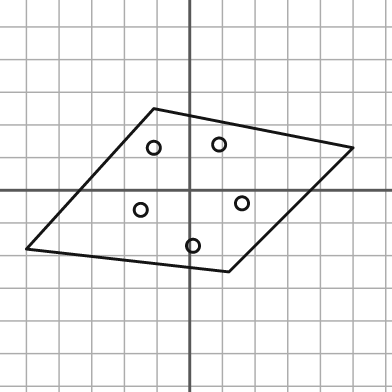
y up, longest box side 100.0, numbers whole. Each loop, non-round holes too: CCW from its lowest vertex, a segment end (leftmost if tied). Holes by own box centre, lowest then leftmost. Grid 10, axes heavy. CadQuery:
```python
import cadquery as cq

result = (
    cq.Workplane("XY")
    .moveTo(12.0, -25.0)
    .lineTo(50.0, 13.0)
    .lineTo(-11.0, 25.0)
    .lineTo(-50.0, -18.0)
    .close()
    .moveTo(1.0, -17.0)
    .circle(2.0)
    .moveTo(-15.0, -6.0)
    .circle(2.0)
    .moveTo(16.0, -4.0)
    .circle(2.0)
    .moveTo(-11.0, 13.0)
    .circle(2.0)
    .moveTo(9.0, 14.0)
    .circle(2.0)
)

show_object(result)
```